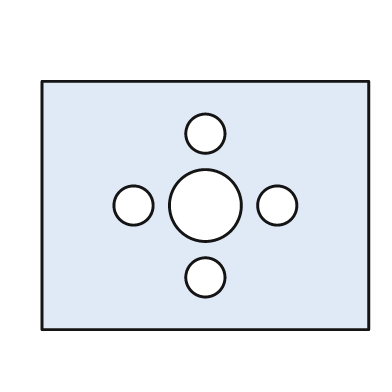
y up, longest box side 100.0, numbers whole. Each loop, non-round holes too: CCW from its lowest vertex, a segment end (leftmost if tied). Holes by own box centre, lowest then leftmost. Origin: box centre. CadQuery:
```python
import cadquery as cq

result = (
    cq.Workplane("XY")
    .moveTo(-50.0, -38.0)
    .lineTo(50.0, -38.0)
    .lineTo(50.0, 38.0)
    .lineTo(-50.0, 38.0)
    .close()
    .moveTo(0.0, -22.0)
    .circle(6.0)
    .moveTo(-22.0, 0.0)
    .circle(6.0)
    .moveTo(0.0, 0.0)
    .circle(11.0)
    .moveTo(22.0, 0.0)
    .circle(6.0)
    .moveTo(0.0, 22.0)
    .circle(6.0)
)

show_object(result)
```